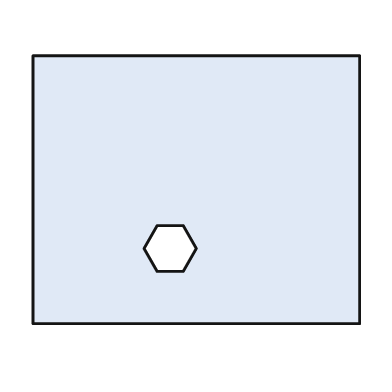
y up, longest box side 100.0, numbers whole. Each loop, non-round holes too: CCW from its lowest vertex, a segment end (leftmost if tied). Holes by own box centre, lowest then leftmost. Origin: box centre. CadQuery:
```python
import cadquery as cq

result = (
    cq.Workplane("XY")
    .moveTo(-50.0, -41.0)
    .lineTo(50.0, -41.0)
    .lineTo(50.0, 41.0)
    .lineTo(-50.0, 41.0)
    .close()
    .moveTo(-12.0, -25.0)
    .lineTo(-4.0, -25.0)
    .lineTo(0.0, -18.0)
    .lineTo(-4.0, -11.0)
    .lineTo(-12.0, -11.0)
    .lineTo(-16.0, -18.0)
    .close()
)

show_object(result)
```